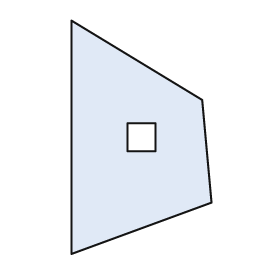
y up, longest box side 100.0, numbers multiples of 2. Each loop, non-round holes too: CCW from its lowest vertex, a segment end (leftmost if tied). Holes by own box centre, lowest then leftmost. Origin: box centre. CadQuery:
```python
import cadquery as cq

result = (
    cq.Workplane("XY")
    .moveTo(-30.0, -50.0)
    .lineTo(30.0, -28.0)
    .lineTo(26.0, 16.0)
    .lineTo(-30.0, 50.0)
    .close()
    .moveTo(-6.0, -6.0)
    .lineTo(6.0, -6.0)
    .lineTo(6.0, 6.0)
    .lineTo(-6.0, 6.0)
    .close()
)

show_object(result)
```